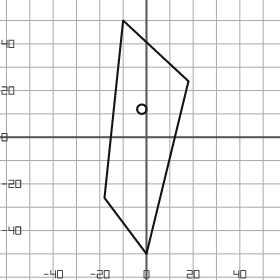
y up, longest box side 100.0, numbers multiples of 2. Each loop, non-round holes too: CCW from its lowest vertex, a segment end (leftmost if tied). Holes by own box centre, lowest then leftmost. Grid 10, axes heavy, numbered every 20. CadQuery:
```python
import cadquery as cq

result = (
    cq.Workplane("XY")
    .moveTo(0.0, -50.0)
    .lineTo(18.0, 24.0)
    .lineTo(-10.0, 50.0)
    .lineTo(-18.0, -26.0)
    .close()
    .moveTo(-2.0, 12.0)
    .circle(2.0)
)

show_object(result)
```